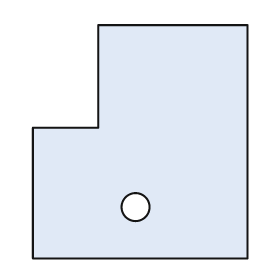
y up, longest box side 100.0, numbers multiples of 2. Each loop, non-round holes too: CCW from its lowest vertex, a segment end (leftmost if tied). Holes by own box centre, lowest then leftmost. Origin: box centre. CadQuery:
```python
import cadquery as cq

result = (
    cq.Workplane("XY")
    .moveTo(-46.0, -50.0)
    .lineTo(46.0, -50.0)
    .lineTo(46.0, 50.0)
    .lineTo(-18.0, 50.0)
    .lineTo(-18.0, 6.0)
    .lineTo(-46.0, 6.0)
    .close()
    .moveTo(-2.0, -28.0)
    .circle(6.0)
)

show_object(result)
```